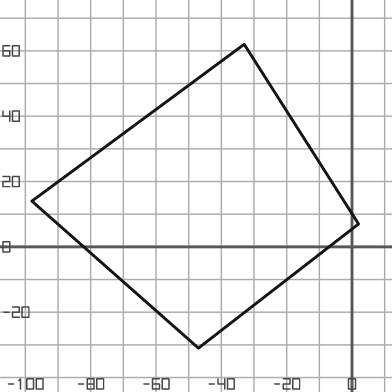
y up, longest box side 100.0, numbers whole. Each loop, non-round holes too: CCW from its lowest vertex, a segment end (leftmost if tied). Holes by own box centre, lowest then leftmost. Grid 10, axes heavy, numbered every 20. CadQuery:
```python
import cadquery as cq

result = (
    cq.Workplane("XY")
    .moveTo(-47.0, -31.0)
    .lineTo(2.0, 7.0)
    .lineTo(-33.0, 62.0)
    .lineTo(-98.0, 14.0)
    .close()
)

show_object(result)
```